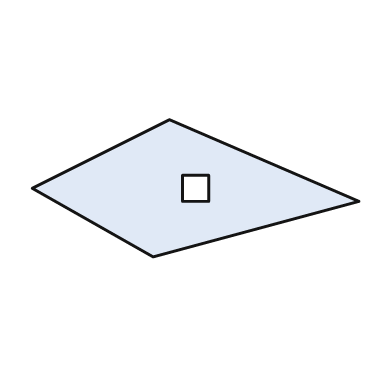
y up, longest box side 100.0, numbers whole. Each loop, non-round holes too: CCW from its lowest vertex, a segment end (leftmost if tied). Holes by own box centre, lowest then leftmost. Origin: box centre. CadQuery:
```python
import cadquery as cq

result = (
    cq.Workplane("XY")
    .moveTo(-13.0, -21.0)
    .lineTo(50.0, -4.0)
    .lineTo(-8.0, 21.0)
    .lineTo(-50.0, 0.0)
    .close()
    .moveTo(-4.0, -4.0)
    .lineTo(4.0, -4.0)
    .lineTo(4.0, 4.0)
    .lineTo(-4.0, 4.0)
    .close()
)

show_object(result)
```